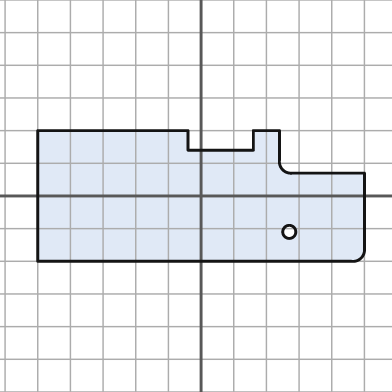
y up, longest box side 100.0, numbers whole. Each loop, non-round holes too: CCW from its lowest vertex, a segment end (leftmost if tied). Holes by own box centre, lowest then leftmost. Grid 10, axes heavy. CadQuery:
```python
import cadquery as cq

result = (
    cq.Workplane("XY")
    .moveTo(-50.0, -20.0)
    .lineTo(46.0, -20.0)
    .threePointArc((49.0, -19.0), (50.0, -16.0))
    .lineTo(50.0, 7.0)
    .lineTo(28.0, 7.0)
    .threePointArc((25.0, 8.0), (24.0, 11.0))
    .lineTo(24.0, 20.0)
    .lineTo(16.0, 20.0)
    .lineTo(16.0, 14.0)
    .lineTo(-4.0, 14.0)
    .lineTo(-4.0, 20.0)
    .lineTo(-50.0, 20.0)
    .close()
    .moveTo(27.0, -11.0)
    .circle(2.0)
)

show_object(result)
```